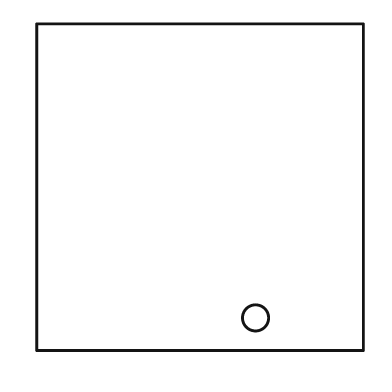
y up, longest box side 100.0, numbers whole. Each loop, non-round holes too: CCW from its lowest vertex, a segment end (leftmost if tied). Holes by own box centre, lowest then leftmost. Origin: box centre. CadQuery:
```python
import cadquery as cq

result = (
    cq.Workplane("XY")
    .moveTo(-50.0, -50.0)
    .lineTo(50.0, -50.0)
    .lineTo(50.0, 50.0)
    .lineTo(-50.0, 50.0)
    .close()
    .moveTo(17.0, -40.0)
    .circle(4.0)
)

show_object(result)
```